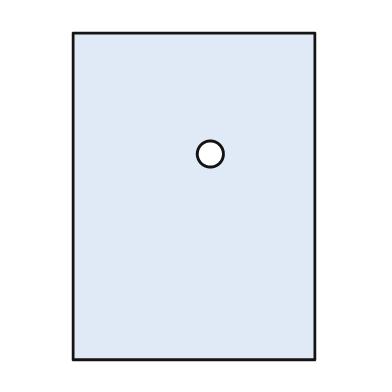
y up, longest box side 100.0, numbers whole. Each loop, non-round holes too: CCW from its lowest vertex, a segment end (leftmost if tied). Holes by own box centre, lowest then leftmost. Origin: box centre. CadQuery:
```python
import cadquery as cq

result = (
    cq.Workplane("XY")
    .moveTo(-37.0, -50.0)
    .lineTo(37.0, -50.0)
    .lineTo(37.0, 50.0)
    .lineTo(-37.0, 50.0)
    .close()
    .moveTo(5.0, 13.0)
    .circle(4.0)
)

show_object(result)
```